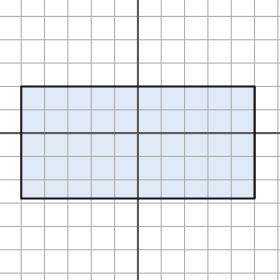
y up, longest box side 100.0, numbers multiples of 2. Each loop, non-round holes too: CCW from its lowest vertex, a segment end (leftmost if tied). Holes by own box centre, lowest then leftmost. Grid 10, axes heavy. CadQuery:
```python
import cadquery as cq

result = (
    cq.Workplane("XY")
    .moveTo(-50.0, -28.0)
    .lineTo(50.0, -28.0)
    .lineTo(50.0, 20.0)
    .lineTo(-50.0, 20.0)
    .close()
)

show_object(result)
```